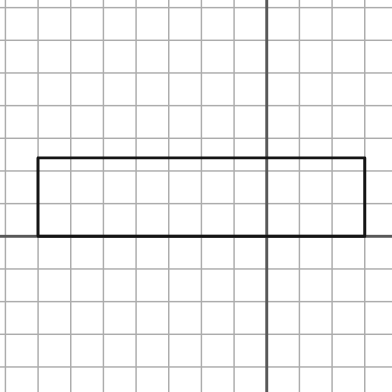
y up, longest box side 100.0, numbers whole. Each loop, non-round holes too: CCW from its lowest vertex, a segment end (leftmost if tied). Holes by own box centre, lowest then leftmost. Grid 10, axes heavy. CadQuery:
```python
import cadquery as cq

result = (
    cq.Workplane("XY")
    .moveTo(-70.0, 0.0)
    .lineTo(30.0, 0.0)
    .lineTo(30.0, 24.0)
    .lineTo(-70.0, 24.0)
    .close()
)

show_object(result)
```